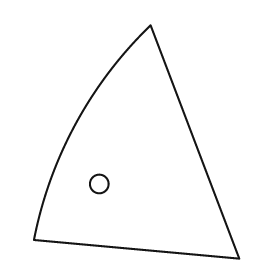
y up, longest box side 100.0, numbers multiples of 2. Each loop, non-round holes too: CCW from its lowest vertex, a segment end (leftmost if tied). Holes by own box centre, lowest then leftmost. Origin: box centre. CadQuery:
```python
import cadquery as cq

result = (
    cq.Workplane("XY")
    .moveTo(44.0, -50.0)
    .lineTo(6.0, 50.0)
    .threePointArc((-26.0, 8.0), (-44.0, -42.0))
    .close()
    .moveTo(-16.0, -18.0)
    .circle(4.0)
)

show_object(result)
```